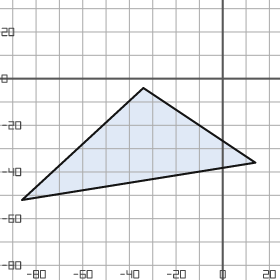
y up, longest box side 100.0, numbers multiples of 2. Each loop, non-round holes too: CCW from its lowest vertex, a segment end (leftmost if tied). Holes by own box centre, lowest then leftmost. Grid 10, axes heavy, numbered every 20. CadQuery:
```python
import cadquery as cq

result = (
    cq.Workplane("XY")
    .moveTo(-86.0, -52.0)
    .lineTo(14.0, -36.0)
    .lineTo(-34.0, -4.0)
    .close()
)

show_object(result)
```